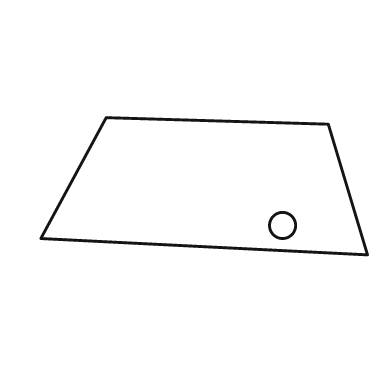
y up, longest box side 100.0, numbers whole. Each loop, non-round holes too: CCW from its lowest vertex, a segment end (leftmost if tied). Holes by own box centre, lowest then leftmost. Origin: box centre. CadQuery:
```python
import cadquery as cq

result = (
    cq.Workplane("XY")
    .moveTo(50.0, -21.0)
    .lineTo(38.0, 19.0)
    .lineTo(-30.0, 21.0)
    .lineTo(-50.0, -16.0)
    .close()
    .moveTo(24.0, -12.0)
    .circle(4.0)
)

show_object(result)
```